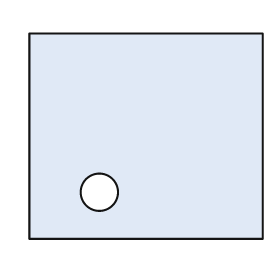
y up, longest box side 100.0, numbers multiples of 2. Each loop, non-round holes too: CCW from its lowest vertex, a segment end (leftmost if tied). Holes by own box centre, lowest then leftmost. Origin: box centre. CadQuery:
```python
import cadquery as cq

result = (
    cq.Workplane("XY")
    .moveTo(-50.0, -44.0)
    .lineTo(50.0, -44.0)
    .lineTo(50.0, 44.0)
    .lineTo(-50.0, 44.0)
    .close()
    .moveTo(-20.0, -24.0)
    .circle(8.0)
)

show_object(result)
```